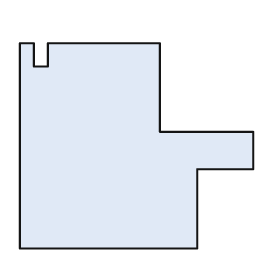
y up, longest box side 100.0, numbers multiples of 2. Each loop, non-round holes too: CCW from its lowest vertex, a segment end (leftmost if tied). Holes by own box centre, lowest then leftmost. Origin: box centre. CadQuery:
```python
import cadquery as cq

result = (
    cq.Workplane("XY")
    .moveTo(-50.0, -44.0)
    .lineTo(26.0, -44.0)
    .lineTo(26.0, -10.0)
    .lineTo(50.0, -10.0)
    .lineTo(50.0, 6.0)
    .lineTo(10.0, 6.0)
    .lineTo(10.0, 44.0)
    .lineTo(-38.0, 44.0)
    .lineTo(-38.0, 34.0)
    .lineTo(-44.0, 34.0)
    .lineTo(-44.0, 44.0)
    .lineTo(-50.0, 44.0)
    .close()
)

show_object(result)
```